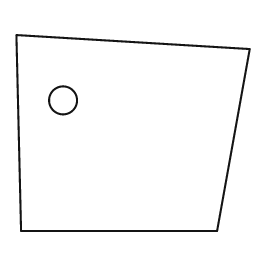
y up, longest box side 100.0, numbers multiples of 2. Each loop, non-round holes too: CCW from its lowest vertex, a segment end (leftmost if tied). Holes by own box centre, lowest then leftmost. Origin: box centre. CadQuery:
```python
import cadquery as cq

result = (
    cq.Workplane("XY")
    .moveTo(-48.0, -42.0)
    .lineTo(36.0, -42.0)
    .lineTo(50.0, 36.0)
    .lineTo(-50.0, 42.0)
    .close()
    .moveTo(-30.0, 14.0)
    .circle(6.0)
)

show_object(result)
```